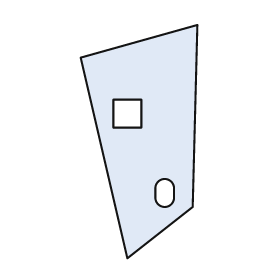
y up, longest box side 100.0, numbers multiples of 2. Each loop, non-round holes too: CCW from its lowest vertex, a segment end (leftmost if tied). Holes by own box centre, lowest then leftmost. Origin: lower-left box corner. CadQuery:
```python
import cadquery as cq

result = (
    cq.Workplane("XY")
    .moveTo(20.0, 0.0)
    .lineTo(48.0, 22.0)
    .lineTo(50.0, 100.0)
    .lineTo(0.0, 86.0)
    .close()
    .moveTo(32.0, 26.0)
    .threePointArc((36.0, 22.0), (40.0, 26.0))
    .lineTo(40.0, 30.0)
    .threePointArc((36.0, 34.0), (32.0, 30.0))
    .close()
    .moveTo(14.0, 56.0)
    .lineTo(26.0, 56.0)
    .lineTo(26.0, 68.0)
    .lineTo(14.0, 68.0)
    .close()
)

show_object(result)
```